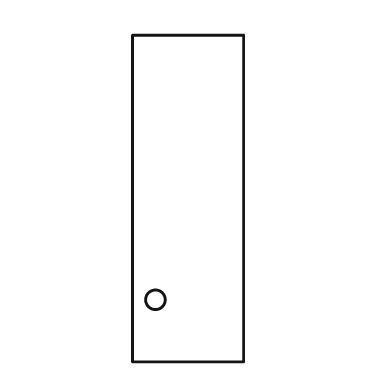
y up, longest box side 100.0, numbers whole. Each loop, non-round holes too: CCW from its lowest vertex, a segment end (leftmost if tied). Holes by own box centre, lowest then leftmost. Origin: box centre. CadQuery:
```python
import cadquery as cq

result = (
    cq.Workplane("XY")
    .moveTo(-17.0, -50.0)
    .lineTo(17.0, -50.0)
    .lineTo(17.0, 50.0)
    .lineTo(-17.0, 50.0)
    .close()
    .moveTo(-10.0, -31.0)
    .circle(3.0)
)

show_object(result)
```